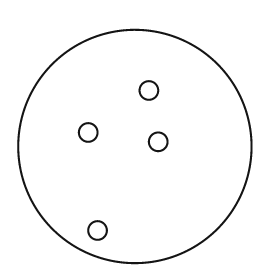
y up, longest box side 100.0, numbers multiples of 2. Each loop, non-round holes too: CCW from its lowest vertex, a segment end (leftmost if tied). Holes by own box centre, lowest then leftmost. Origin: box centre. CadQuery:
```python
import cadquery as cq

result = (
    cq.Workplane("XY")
    .moveTo(0.0, 0.0)
    .circle(50.0)
    .moveTo(-16.0, -36.0)
    .circle(4.0)
    .moveTo(10.0, 2.0)
    .circle(4.0)
    .moveTo(-20.0, 6.0)
    .circle(4.0)
    .moveTo(6.0, 24.0)
    .circle(4.0)
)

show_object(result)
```